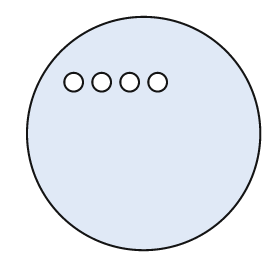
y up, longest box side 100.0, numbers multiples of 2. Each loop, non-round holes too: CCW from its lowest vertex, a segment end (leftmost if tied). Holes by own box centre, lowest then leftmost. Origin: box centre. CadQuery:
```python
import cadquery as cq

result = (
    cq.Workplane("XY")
    .moveTo(0.0, 0.0)
    .circle(50.0)
    .moveTo(-30.0, 22.0)
    .circle(4.0)
    .moveTo(-18.0, 22.0)
    .circle(4.0)
    .moveTo(-6.0, 22.0)
    .circle(4.0)
    .moveTo(6.0, 22.0)
    .circle(4.0)
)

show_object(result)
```